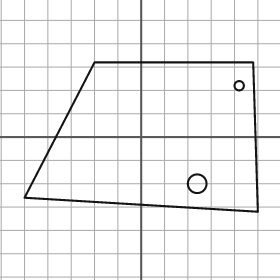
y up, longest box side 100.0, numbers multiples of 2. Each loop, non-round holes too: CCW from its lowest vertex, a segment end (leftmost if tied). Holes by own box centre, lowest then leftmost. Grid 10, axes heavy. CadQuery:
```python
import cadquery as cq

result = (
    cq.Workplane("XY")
    .moveTo(50.0, -32.0)
    .lineTo(48.0, 32.0)
    .lineTo(-20.0, 32.0)
    .lineTo(-50.0, -26.0)
    .close()
    .moveTo(24.0, -20.0)
    .circle(4.0)
    .moveTo(42.0, 22.0)
    .circle(2.0)
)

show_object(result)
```